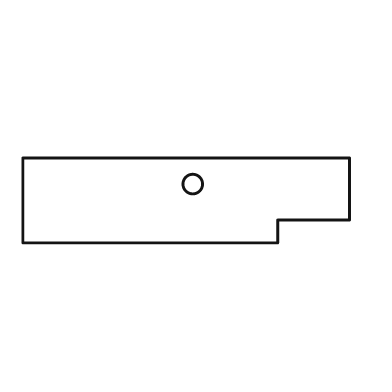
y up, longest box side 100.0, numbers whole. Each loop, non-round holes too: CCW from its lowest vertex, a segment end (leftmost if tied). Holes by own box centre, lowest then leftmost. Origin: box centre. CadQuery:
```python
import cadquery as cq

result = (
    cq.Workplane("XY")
    .moveTo(-50.0, -13.0)
    .lineTo(28.0, -13.0)
    .lineTo(28.0, -6.0)
    .lineTo(50.0, -6.0)
    .lineTo(50.0, 13.0)
    .lineTo(-50.0, 13.0)
    .close()
    .moveTo(2.0, 5.0)
    .circle(3.0)
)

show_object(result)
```